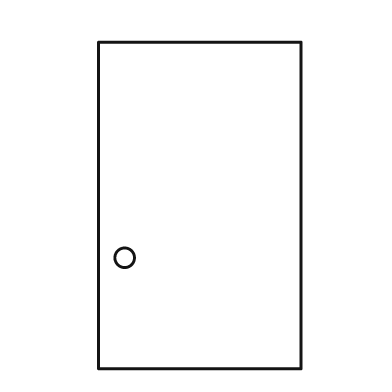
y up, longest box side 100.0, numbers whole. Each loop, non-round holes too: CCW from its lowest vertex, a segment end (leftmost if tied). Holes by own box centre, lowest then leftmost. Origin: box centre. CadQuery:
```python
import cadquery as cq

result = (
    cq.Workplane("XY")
    .moveTo(-31.0, -50.0)
    .lineTo(31.0, -50.0)
    .lineTo(31.0, 50.0)
    .lineTo(-31.0, 50.0)
    .close()
    .moveTo(-23.0, -16.0)
    .circle(3.0)
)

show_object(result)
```